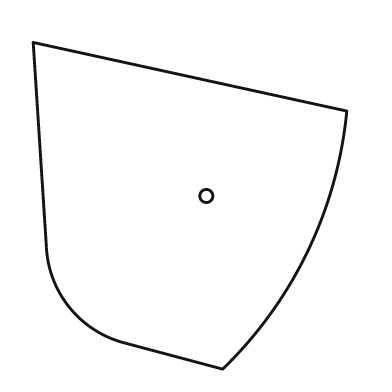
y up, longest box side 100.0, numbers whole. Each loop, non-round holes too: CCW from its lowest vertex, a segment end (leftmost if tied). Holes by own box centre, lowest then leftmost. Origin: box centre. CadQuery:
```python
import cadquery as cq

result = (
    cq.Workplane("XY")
    .moveTo(10.0, -50.0)
    .threePointArc((36.0, -14.0), (48.0, 29.0))
    .lineTo(-48.0, 50.0)
    .lineTo(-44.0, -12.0)
    .threePointArc((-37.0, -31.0), (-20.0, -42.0))
    .close()
    .moveTo(5.0, 3.0)
    .circle(2.0)
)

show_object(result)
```